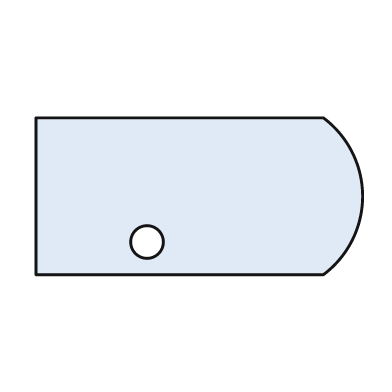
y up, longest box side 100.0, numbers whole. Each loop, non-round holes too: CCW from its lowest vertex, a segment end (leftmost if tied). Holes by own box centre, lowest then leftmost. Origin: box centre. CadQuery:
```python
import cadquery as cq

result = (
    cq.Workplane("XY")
    .moveTo(-50.0, -24.0)
    .lineTo(38.0, -24.0)
    .threePointArc((50.0, 0.0), (38.0, 24.0))
    .lineTo(-50.0, 24.0)
    .close()
    .moveTo(-16.0, -14.0)
    .circle(5.0)
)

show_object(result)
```